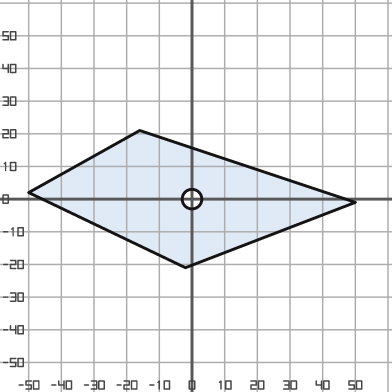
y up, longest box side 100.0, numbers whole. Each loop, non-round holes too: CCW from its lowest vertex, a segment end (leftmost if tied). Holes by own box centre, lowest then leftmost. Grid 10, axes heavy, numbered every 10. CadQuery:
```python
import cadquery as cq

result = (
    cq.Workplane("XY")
    .moveTo(-2.0, -21.0)
    .lineTo(50.0, -1.0)
    .lineTo(-16.0, 21.0)
    .lineTo(-50.0, 2.0)
    .close()
    .moveTo(0.0, 0.0)
    .circle(3.0)
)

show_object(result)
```